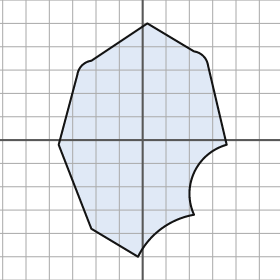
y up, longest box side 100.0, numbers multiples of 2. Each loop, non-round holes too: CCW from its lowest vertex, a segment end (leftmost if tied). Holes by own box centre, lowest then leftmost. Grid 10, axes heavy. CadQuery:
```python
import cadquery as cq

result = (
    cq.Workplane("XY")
    .moveTo(-2.0, -50.0)
    .threePointArc((8.0, -38.0), (22.0, -32.0))
    .threePointArc((22.0, -14.0), (36.0, -2.0))
    .lineTo(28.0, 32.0)
    .threePointArc((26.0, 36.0), (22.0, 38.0))
    .lineTo(2.0, 50.0)
    .lineTo(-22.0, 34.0)
    .threePointArc((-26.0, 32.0), (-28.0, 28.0))
    .lineTo(-36.0, -2.0)
    .lineTo(-22.0, -38.0)
    .close()
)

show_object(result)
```